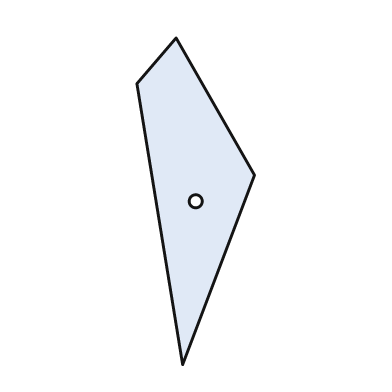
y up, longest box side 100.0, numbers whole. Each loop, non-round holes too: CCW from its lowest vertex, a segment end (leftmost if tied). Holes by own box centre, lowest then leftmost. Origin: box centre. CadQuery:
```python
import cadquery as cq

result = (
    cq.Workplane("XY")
    .moveTo(-4.0, -50.0)
    .lineTo(18.0, 8.0)
    .lineTo(-6.0, 50.0)
    .lineTo(-18.0, 36.0)
    .close()
    .moveTo(0.0, 0.0)
    .circle(2.0)
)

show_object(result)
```